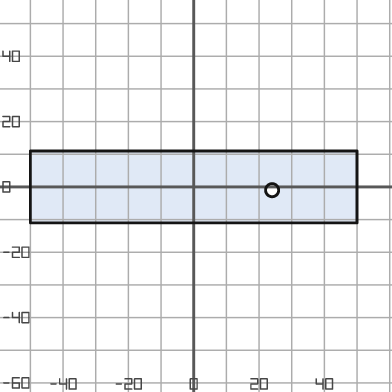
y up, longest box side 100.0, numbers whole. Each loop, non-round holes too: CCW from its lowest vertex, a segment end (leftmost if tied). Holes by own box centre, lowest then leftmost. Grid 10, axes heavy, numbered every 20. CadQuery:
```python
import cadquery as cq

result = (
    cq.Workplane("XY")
    .moveTo(-50.0, -11.0)
    .lineTo(50.0, -11.0)
    .lineTo(50.0, 11.0)
    .lineTo(-50.0, 11.0)
    .close()
    .moveTo(24.0, -1.0)
    .circle(2.0)
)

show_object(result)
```